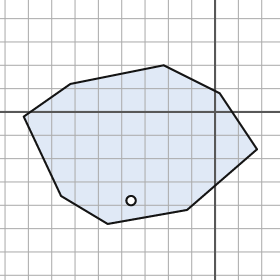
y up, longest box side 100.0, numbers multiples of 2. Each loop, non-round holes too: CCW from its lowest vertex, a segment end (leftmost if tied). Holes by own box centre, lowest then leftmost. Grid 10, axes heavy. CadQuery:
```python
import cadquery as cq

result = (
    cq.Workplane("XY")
    .moveTo(-46.0, -48.0)
    .lineTo(-12.0, -42.0)
    .lineTo(18.0, -16.0)
    .lineTo(2.0, 8.0)
    .lineTo(-22.0, 20.0)
    .lineTo(-62.0, 12.0)
    .lineTo(-82.0, -2.0)
    .lineTo(-66.0, -36.0)
    .close()
    .moveTo(-36.0, -38.0)
    .circle(2.0)
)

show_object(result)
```